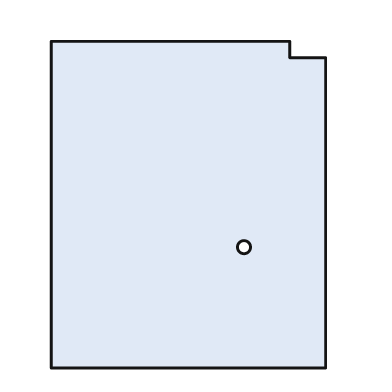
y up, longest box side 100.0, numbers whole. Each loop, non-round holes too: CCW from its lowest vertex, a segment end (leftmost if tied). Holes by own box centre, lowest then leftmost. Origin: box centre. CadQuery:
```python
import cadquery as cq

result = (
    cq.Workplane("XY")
    .moveTo(-42.0, -50.0)
    .lineTo(42.0, -50.0)
    .lineTo(42.0, 45.0)
    .lineTo(31.0, 45.0)
    .lineTo(31.0, 50.0)
    .lineTo(-42.0, 50.0)
    .close()
    .moveTo(17.0, -13.0)
    .circle(2.0)
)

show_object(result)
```